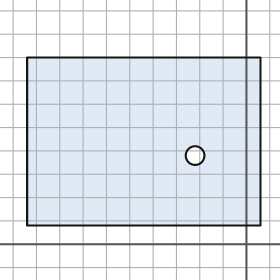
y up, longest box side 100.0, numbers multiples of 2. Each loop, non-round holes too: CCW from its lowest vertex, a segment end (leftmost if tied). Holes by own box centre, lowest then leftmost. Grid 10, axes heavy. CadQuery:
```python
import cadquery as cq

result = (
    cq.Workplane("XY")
    .moveTo(-94.0, 8.0)
    .lineTo(6.0, 8.0)
    .lineTo(6.0, 80.0)
    .lineTo(-94.0, 80.0)
    .close()
    .moveTo(-22.0, 38.0)
    .circle(4.0)
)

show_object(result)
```